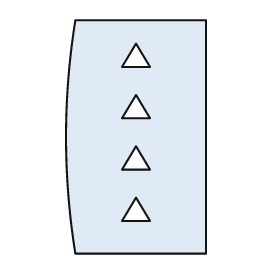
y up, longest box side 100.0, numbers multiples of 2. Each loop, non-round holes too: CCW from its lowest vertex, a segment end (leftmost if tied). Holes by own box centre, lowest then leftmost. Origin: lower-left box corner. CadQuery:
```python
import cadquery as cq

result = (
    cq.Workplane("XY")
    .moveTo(4.0, 0.0)
    .lineTo(60.0, 0.0)
    .lineTo(60.0, 100.0)
    .lineTo(4.0, 100.0)
    .threePointArc((0.0, 50.0), (4.0, 0.0))
    .close()
    .moveTo(24.0, 14.0)
    .lineTo(36.0, 14.0)
    .lineTo(30.0, 24.0)
    .close()
    .moveTo(24.0, 36.0)
    .lineTo(36.0, 36.0)
    .lineTo(30.0, 46.0)
    .close()
    .moveTo(24.0, 58.0)
    .lineTo(36.0, 58.0)
    .lineTo(30.0, 68.0)
    .close()
    .moveTo(24.0, 80.0)
    .lineTo(36.0, 80.0)
    .lineTo(30.0, 90.0)
    .close()
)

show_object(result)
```